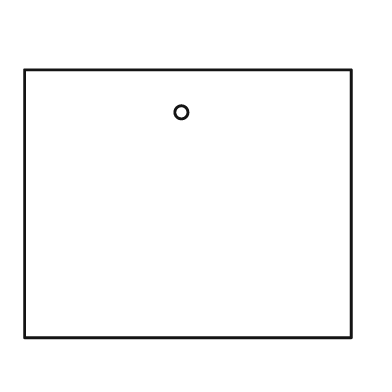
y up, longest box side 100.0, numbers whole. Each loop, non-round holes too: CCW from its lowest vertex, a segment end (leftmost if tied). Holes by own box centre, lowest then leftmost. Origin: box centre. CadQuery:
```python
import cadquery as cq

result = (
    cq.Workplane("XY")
    .moveTo(-50.0, -41.0)
    .lineTo(50.0, -41.0)
    .lineTo(50.0, 41.0)
    .lineTo(-50.0, 41.0)
    .close()
    .moveTo(-2.0, 28.0)
    .circle(2.0)
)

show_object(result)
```